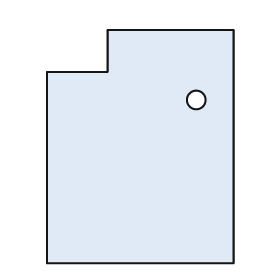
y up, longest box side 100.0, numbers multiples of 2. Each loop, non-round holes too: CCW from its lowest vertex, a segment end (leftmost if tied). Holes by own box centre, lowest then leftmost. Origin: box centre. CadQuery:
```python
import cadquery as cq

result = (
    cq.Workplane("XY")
    .moveTo(-40.0, -50.0)
    .lineTo(40.0, -50.0)
    .lineTo(40.0, 50.0)
    .lineTo(-14.0, 50.0)
    .lineTo(-14.0, 32.0)
    .lineTo(-40.0, 32.0)
    .close()
    .moveTo(24.0, 20.0)
    .circle(4.0)
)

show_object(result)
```